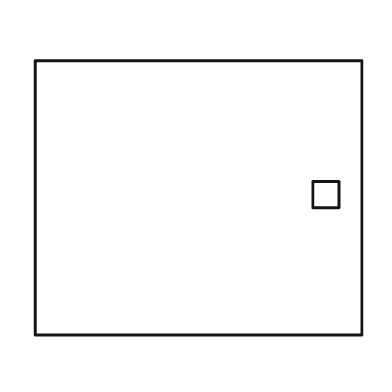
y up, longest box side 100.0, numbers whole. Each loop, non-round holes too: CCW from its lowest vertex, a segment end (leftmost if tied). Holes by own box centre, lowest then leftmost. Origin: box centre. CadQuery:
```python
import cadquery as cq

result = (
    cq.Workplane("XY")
    .moveTo(-50.0, -42.0)
    .lineTo(50.0, -42.0)
    .lineTo(50.0, 42.0)
    .lineTo(-50.0, 42.0)
    .close()
    .moveTo(35.0, -3.0)
    .lineTo(43.0, -3.0)
    .lineTo(43.0, 5.0)
    .lineTo(35.0, 5.0)
    .close()
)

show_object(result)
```